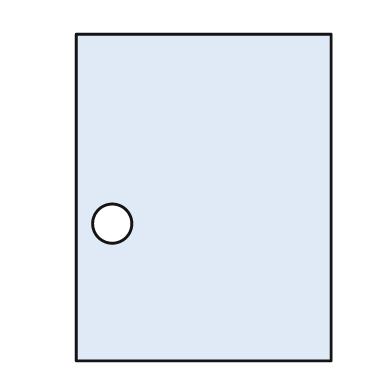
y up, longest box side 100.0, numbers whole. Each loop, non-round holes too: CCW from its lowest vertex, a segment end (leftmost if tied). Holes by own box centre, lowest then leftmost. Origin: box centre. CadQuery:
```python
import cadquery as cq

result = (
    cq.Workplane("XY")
    .moveTo(-39.0, -50.0)
    .lineTo(39.0, -50.0)
    .lineTo(39.0, 50.0)
    .lineTo(-39.0, 50.0)
    .close()
    .moveTo(-28.0, -8.0)
    .circle(6.0)
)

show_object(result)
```